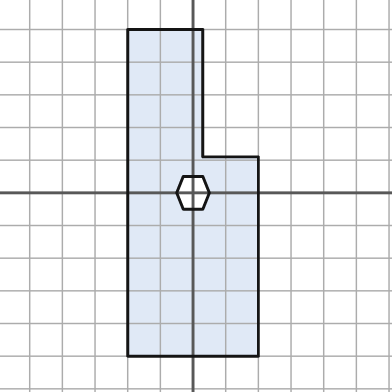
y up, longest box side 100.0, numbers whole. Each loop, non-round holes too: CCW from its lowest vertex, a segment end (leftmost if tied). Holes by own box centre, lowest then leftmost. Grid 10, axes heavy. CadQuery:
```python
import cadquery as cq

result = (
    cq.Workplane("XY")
    .moveTo(-20.0, -50.0)
    .lineTo(20.0, -50.0)
    .lineTo(20.0, 11.0)
    .lineTo(3.0, 11.0)
    .lineTo(3.0, 50.0)
    .lineTo(-20.0, 50.0)
    .close()
    .moveTo(-3.0, -5.0)
    .lineTo(3.0, -5.0)
    .lineTo(5.0, 0.0)
    .lineTo(3.0, 5.0)
    .lineTo(-3.0, 5.0)
    .lineTo(-5.0, 0.0)
    .close()
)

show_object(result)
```